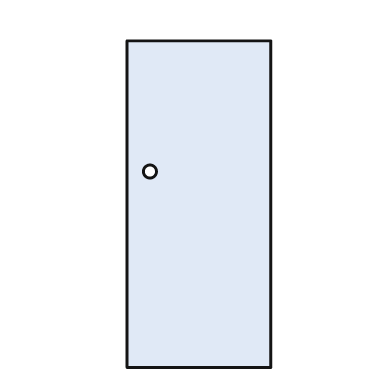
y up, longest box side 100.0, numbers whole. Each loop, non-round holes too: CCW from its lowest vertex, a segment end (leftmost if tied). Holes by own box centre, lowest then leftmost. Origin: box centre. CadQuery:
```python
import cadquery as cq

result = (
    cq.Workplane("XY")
    .moveTo(-22.0, -50.0)
    .lineTo(22.0, -50.0)
    .lineTo(22.0, 50.0)
    .lineTo(-22.0, 50.0)
    .close()
    .moveTo(-15.0, 10.0)
    .circle(2.0)
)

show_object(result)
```